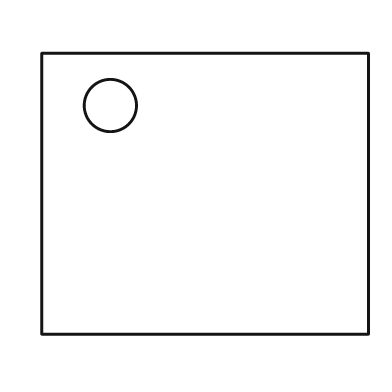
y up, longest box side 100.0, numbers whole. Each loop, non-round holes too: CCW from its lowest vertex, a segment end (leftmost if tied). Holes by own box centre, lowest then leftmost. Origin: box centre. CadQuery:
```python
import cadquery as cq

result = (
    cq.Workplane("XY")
    .moveTo(-50.0, -43.0)
    .lineTo(50.0, -43.0)
    .lineTo(50.0, 43.0)
    .lineTo(-50.0, 43.0)
    .close()
    .moveTo(-29.0, 27.0)
    .circle(8.0)
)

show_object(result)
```